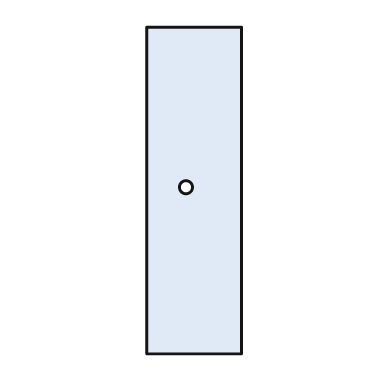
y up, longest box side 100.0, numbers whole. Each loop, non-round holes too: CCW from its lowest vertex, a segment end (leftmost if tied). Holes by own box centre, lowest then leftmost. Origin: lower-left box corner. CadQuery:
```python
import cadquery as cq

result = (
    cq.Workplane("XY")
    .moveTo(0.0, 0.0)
    .lineTo(29.0, 0.0)
    .lineTo(29.0, 100.0)
    .lineTo(0.0, 100.0)
    .close()
    .moveTo(12.0, 51.0)
    .circle(2.0)
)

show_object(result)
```